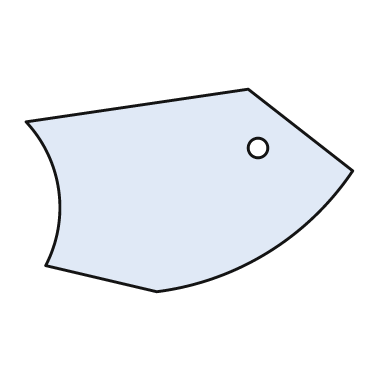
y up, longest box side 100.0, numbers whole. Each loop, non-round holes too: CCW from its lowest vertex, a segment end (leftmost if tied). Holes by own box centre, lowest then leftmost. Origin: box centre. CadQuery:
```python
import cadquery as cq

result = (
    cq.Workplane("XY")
    .moveTo(-10.0, -31.0)
    .threePointArc((24.0, -19.0), (50.0, 6.0))
    .lineTo(18.0, 31.0)
    .lineTo(-50.0, 21.0)
    .threePointArc((-40.0, 0.0), (-44.0, -23.0))
    .close()
    .moveTo(21.0, 13.0)
    .circle(3.0)
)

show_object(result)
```